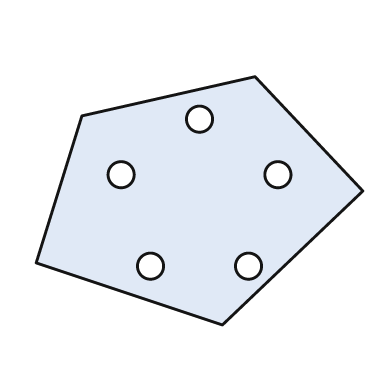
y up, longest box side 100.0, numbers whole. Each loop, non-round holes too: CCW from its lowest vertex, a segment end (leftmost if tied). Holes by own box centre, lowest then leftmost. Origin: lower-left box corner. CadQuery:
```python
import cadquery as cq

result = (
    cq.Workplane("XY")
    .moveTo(57.0, 0.0)
    .lineTo(100.0, 41.0)
    .lineTo(67.0, 76.0)
    .lineTo(14.0, 64.0)
    .lineTo(0.0, 19.0)
    .close()
    .moveTo(35.0, 18.0)
    .circle(4.0)
    .moveTo(65.0, 18.0)
    .circle(4.0)
    .moveTo(26.0, 46.0)
    .circle(4.0)
    .moveTo(74.0, 46.0)
    .circle(4.0)
    .moveTo(50.0, 63.0)
    .circle(4.0)
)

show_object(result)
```